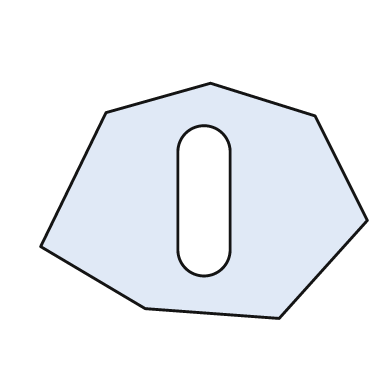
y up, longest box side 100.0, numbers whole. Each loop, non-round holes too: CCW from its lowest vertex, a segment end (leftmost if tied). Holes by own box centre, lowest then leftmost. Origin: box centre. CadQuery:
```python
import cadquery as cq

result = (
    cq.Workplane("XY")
    .moveTo(23.0, -36.0)
    .lineTo(50.0, -6.0)
    .lineTo(34.0, 26.0)
    .lineTo(2.0, 36.0)
    .lineTo(-30.0, 27.0)
    .lineTo(-50.0, -14.0)
    .lineTo(-18.0, -33.0)
    .close()
    .moveTo(-8.0, -15.0)
    .threePointArc((0.0, -23.0), (8.0, -15.0))
    .lineTo(8.0, 15.0)
    .threePointArc((0.0, 23.0), (-8.0, 15.0))
    .close()
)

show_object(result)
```